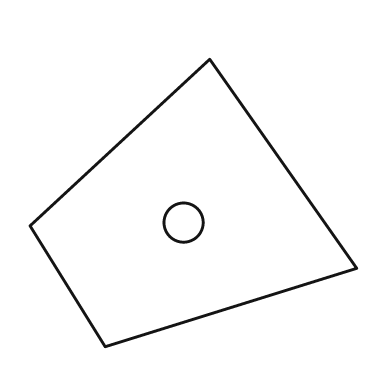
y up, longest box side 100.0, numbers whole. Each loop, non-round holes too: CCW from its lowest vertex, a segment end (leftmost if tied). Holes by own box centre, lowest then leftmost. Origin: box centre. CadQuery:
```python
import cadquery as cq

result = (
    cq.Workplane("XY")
    .moveTo(-27.0, -44.0)
    .lineTo(50.0, -20.0)
    .lineTo(5.0, 44.0)
    .lineTo(-50.0, -7.0)
    .close()
    .moveTo(-3.0, -6.0)
    .circle(6.0)
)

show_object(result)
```